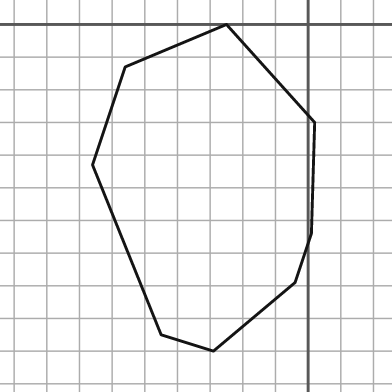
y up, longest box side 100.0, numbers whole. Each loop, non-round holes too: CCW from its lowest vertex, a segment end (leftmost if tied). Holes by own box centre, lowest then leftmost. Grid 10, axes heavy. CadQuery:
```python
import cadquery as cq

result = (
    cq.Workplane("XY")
    .moveTo(-29.0, -100.0)
    .lineTo(-4.0, -79.0)
    .lineTo(1.0, -64.0)
    .lineTo(2.0, -30.0)
    .lineTo(-25.0, 0.0)
    .lineTo(-56.0, -13.0)
    .lineTo(-66.0, -43.0)
    .lineTo(-45.0, -95.0)
    .close()
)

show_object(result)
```